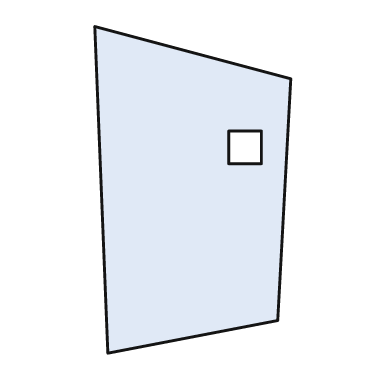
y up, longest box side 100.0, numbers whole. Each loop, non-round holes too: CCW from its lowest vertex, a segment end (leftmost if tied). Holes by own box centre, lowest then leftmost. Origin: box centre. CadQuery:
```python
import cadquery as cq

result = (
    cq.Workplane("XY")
    .moveTo(-26.0, -50.0)
    .lineTo(26.0, -40.0)
    .lineTo(30.0, 34.0)
    .lineTo(-30.0, 50.0)
    .close()
    .moveTo(11.0, 8.0)
    .lineTo(21.0, 8.0)
    .lineTo(21.0, 18.0)
    .lineTo(11.0, 18.0)
    .close()
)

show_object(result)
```